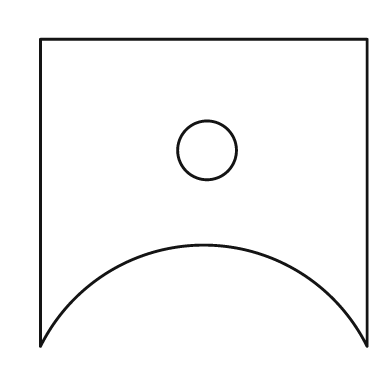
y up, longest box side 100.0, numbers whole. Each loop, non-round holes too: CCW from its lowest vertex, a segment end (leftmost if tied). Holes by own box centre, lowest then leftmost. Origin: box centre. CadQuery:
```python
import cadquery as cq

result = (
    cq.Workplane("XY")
    .moveTo(-50.0, -47.0)
    .threePointArc((0.0, -16.0), (50.0, -47.0))
    .lineTo(50.0, 47.0)
    .lineTo(-50.0, 47.0)
    .close()
    .moveTo(1.0, 13.0)
    .circle(9.0)
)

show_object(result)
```